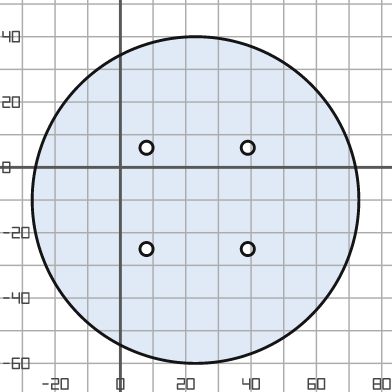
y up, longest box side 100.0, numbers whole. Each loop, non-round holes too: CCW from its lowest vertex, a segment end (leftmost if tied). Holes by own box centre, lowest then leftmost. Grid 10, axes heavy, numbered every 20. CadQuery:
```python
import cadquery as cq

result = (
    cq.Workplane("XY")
    .moveTo(23.0, -10.0)
    .circle(50.0)
    .moveTo(8.0, -25.0)
    .circle(2.0)
    .moveTo(39.0, -25.0)
    .circle(2.0)
    .moveTo(8.0, 6.0)
    .circle(2.0)
    .moveTo(39.0, 6.0)
    .circle(2.0)
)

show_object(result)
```